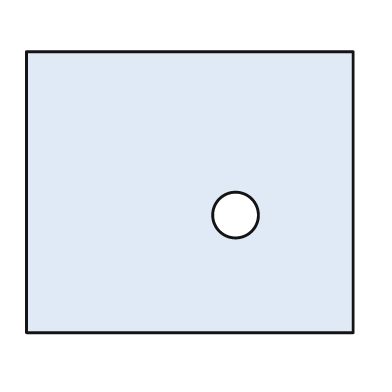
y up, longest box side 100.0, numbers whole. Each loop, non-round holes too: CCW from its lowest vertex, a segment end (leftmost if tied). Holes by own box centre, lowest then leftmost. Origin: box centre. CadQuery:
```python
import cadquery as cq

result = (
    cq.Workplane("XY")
    .moveTo(-50.0, -43.0)
    .lineTo(50.0, -43.0)
    .lineTo(50.0, 43.0)
    .lineTo(-50.0, 43.0)
    .close()
    .moveTo(14.0, -7.0)
    .circle(7.0)
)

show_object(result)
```